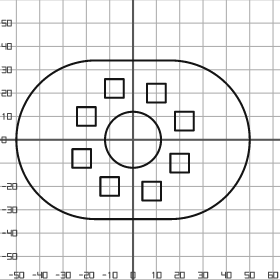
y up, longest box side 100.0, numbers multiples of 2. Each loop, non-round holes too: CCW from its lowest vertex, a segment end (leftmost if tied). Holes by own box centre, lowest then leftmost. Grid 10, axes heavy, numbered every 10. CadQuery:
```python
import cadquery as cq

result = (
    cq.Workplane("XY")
    .moveTo(-16.0, -34.0)
    .lineTo(16.0, -34.0)
    .threePointArc((50.0, 0.0), (16.0, 34.0))
    .lineTo(-16.0, 34.0)
    .threePointArc((-50.0, 0.0), (-16.0, -34.0))
    .close()
    .moveTo(4.0, -26.0)
    .lineTo(12.0, -26.0)
    .lineTo(12.0, -18.0)
    .lineTo(4.0, -18.0)
    .close()
    .moveTo(-14.0, -24.0)
    .lineTo(-6.0, -24.0)
    .lineTo(-6.0, -16.0)
    .lineTo(-14.0, -16.0)
    .close()
    .moveTo(16.0, -14.0)
    .lineTo(24.0, -14.0)
    .lineTo(24.0, -6.0)
    .lineTo(16.0, -6.0)
    .close()
    .moveTo(-26.0, -12.0)
    .lineTo(-18.0, -12.0)
    .lineTo(-18.0, -4.0)
    .lineTo(-26.0, -4.0)
    .close()
    .moveTo(0.0, 0.0)
    .circle(12.0)
    .moveTo(18.0, 4.0)
    .lineTo(26.0, 4.0)
    .lineTo(26.0, 12.0)
    .lineTo(18.0, 12.0)
    .close()
    .moveTo(-24.0, 6.0)
    .lineTo(-16.0, 6.0)
    .lineTo(-16.0, 14.0)
    .lineTo(-24.0, 14.0)
    .close()
    .moveTo(6.0, 16.0)
    .lineTo(14.0, 16.0)
    .lineTo(14.0, 24.0)
    .lineTo(6.0, 24.0)
    .close()
    .moveTo(-12.0, 18.0)
    .lineTo(-4.0, 18.0)
    .lineTo(-4.0, 26.0)
    .lineTo(-12.0, 26.0)
    .close()
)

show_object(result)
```